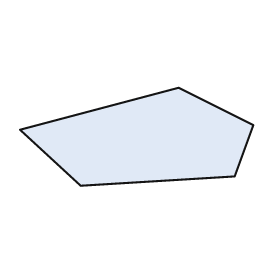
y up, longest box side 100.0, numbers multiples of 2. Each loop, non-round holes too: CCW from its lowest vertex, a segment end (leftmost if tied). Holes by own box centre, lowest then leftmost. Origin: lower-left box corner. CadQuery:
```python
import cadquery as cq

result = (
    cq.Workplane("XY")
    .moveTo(26.0, 0.0)
    .lineTo(92.0, 4.0)
    .lineTo(100.0, 26.0)
    .lineTo(68.0, 42.0)
    .lineTo(0.0, 24.0)
    .close()
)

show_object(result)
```